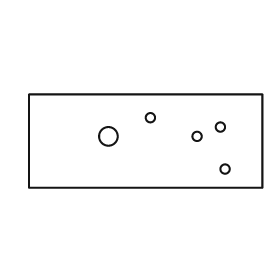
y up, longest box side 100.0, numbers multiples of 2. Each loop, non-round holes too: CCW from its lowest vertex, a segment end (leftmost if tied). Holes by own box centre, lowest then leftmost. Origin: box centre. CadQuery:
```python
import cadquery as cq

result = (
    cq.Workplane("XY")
    .moveTo(-50.0, -20.0)
    .lineTo(50.0, -20.0)
    .lineTo(50.0, 20.0)
    .lineTo(-50.0, 20.0)
    .close()
    .moveTo(34.0, -12.0)
    .circle(2.0)
    .moveTo(-16.0, 2.0)
    .circle(4.0)
    .moveTo(22.0, 2.0)
    .circle(2.0)
    .moveTo(32.0, 6.0)
    .circle(2.0)
    .moveTo(2.0, 10.0)
    .circle(2.0)
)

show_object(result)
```